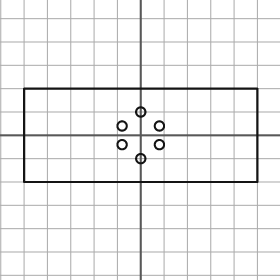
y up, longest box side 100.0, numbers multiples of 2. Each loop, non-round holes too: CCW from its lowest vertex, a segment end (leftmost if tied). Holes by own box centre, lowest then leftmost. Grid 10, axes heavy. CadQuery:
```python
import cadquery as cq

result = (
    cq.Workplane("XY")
    .moveTo(-50.0, -20.0)
    .lineTo(50.0, -20.0)
    .lineTo(50.0, 20.0)
    .lineTo(-50.0, 20.0)
    .close()
    .moveTo(0.0, -10.0)
    .circle(2.0)
    .moveTo(-8.0, -4.0)
    .circle(2.0)
    .moveTo(8.0, -4.0)
    .circle(2.0)
    .moveTo(-8.0, 4.0)
    .circle(2.0)
    .moveTo(8.0, 4.0)
    .circle(2.0)
    .moveTo(0.0, 10.0)
    .circle(2.0)
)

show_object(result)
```